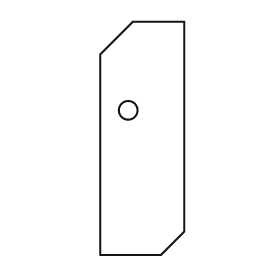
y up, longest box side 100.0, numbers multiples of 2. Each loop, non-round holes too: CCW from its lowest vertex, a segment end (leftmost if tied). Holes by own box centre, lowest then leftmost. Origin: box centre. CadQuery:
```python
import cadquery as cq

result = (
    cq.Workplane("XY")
    .moveTo(-18.0, -50.0)
    .lineTo(8.0, -50.0)
    .lineTo(18.0, -40.0)
    .lineTo(18.0, 50.0)
    .lineTo(-4.0, 50.0)
    .lineTo(-18.0, 36.0)
    .close()
    .moveTo(-6.0, 12.0)
    .circle(4.0)
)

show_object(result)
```